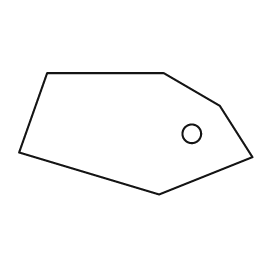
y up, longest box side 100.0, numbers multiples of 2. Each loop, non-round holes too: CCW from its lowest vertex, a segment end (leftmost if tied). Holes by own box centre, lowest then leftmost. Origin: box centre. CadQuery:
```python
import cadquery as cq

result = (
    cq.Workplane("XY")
    .moveTo(10.0, -26.0)
    .lineTo(50.0, -10.0)
    .lineTo(36.0, 12.0)
    .lineTo(12.0, 26.0)
    .lineTo(-38.0, 26.0)
    .lineTo(-50.0, -8.0)
    .close()
    .moveTo(24.0, 0.0)
    .circle(4.0)
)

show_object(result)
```